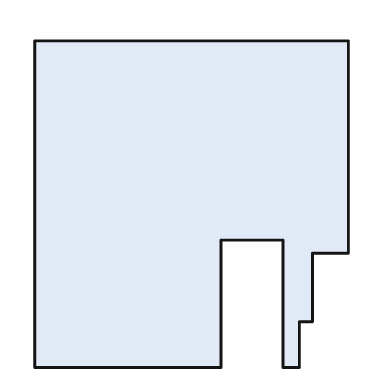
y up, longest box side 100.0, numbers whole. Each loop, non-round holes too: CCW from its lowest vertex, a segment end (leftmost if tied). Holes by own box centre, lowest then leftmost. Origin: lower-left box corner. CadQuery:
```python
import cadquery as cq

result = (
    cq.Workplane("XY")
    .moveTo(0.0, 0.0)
    .lineTo(57.0, 0.0)
    .lineTo(57.0, 39.0)
    .lineTo(76.0, 39.0)
    .lineTo(76.0, 0.0)
    .lineTo(81.0, 0.0)
    .lineTo(81.0, 14.0)
    .lineTo(85.0, 14.0)
    .lineTo(85.0, 35.0)
    .lineTo(96.0, 35.0)
    .lineTo(96.0, 100.0)
    .lineTo(0.0, 100.0)
    .close()
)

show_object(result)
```